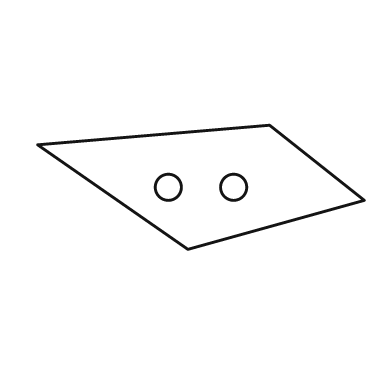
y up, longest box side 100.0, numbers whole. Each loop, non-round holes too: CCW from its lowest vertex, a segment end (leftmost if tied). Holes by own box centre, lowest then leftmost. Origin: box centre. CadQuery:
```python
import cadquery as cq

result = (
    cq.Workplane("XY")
    .moveTo(-4.0, -19.0)
    .lineTo(50.0, -4.0)
    .lineTo(21.0, 19.0)
    .lineTo(-50.0, 13.0)
    .close()
    .moveTo(-10.0, 0.0)
    .circle(4.0)
    .moveTo(10.0, 0.0)
    .circle(4.0)
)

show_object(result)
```